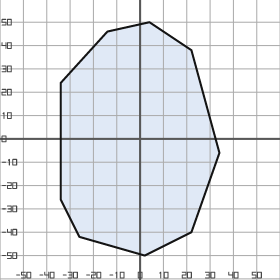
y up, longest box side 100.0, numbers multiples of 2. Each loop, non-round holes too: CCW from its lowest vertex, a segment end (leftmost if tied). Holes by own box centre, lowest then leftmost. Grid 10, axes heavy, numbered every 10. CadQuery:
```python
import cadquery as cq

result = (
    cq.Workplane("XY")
    .moveTo(2.0, -50.0)
    .lineTo(22.0, -40.0)
    .lineTo(34.0, -6.0)
    .lineTo(22.0, 38.0)
    .lineTo(4.0, 50.0)
    .lineTo(-14.0, 46.0)
    .lineTo(-34.0, 24.0)
    .lineTo(-34.0, -26.0)
    .lineTo(-26.0, -42.0)
    .close()
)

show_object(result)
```